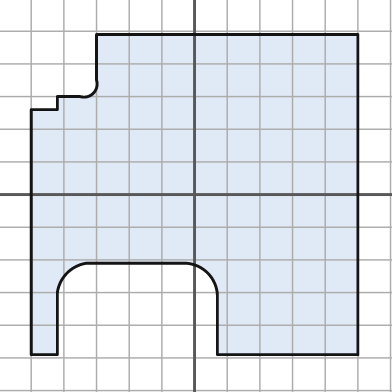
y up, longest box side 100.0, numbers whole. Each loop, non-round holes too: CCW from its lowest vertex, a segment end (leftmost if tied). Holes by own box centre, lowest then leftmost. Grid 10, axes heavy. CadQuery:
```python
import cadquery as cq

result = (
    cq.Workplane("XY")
    .moveTo(-50.0, -49.0)
    .lineTo(-42.0, -49.0)
    .lineTo(-42.0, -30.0)
    .threePointArc((-39.0, -24.0), (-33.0, -21.0))
    .lineTo(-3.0, -21.0)
    .threePointArc((4.0, -24.0), (7.0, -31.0))
    .lineTo(7.0, -49.0)
    .lineTo(50.0, -49.0)
    .lineTo(50.0, 49.0)
    .lineTo(-30.0, 49.0)
    .lineTo(-30.0, 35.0)
    .threePointArc((-31.0, 31.0), (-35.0, 30.0))
    .lineTo(-42.0, 30.0)
    .lineTo(-42.0, 26.0)
    .lineTo(-50.0, 26.0)
    .close()
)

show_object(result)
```